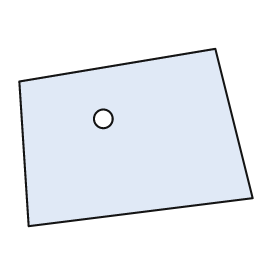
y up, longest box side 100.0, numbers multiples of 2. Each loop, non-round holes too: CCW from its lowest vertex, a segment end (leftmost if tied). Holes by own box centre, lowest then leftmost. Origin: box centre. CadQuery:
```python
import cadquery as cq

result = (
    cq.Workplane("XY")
    .moveTo(-46.0, -38.0)
    .lineTo(50.0, -26.0)
    .lineTo(34.0, 38.0)
    .lineTo(-50.0, 24.0)
    .close()
    .moveTo(-14.0, 8.0)
    .circle(4.0)
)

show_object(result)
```